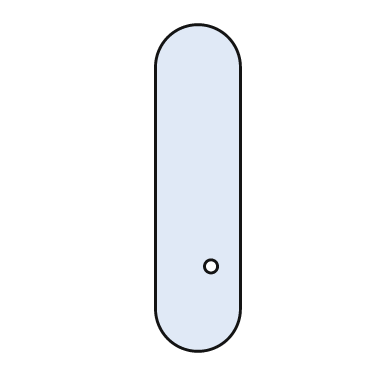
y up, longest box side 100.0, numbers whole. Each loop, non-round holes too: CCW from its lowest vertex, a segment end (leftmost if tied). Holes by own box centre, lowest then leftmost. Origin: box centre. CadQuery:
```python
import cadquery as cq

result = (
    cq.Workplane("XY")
    .moveTo(-13.0, -37.0)
    .threePointArc((0.0, -50.0), (13.0, -37.0))
    .lineTo(13.0, 37.0)
    .threePointArc((0.0, 50.0), (-13.0, 37.0))
    .close()
    .moveTo(4.0, -24.0)
    .circle(2.0)
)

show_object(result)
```